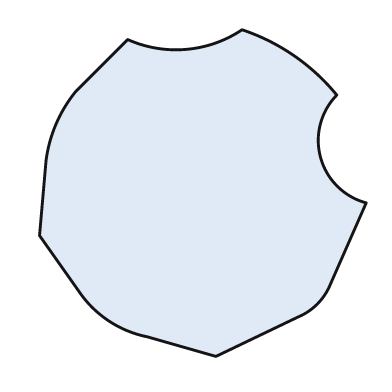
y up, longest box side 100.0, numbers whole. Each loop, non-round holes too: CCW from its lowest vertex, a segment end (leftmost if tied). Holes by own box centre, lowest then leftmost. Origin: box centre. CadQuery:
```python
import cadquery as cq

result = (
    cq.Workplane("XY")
    .moveTo(4.0, -50.0)
    .lineTo(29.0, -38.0)
    .threePointArc((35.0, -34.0), (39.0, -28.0))
    .lineTo(50.0, -3.0)
    .threePointArc((36.0, 11.0), (41.0, 30.0))
    .threePointArc((28.0, 42.0), (12.0, 50.0))
    .threePointArc((-5.0, 44.0), (-23.0, 47.0))
    .lineTo(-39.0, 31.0)
    .threePointArc((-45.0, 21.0), (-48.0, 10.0))
    .lineTo(-50.0, -13.0)
    .lineTo(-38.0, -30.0)
    .threePointArc((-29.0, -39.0), (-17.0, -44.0))
    .close()
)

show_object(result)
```